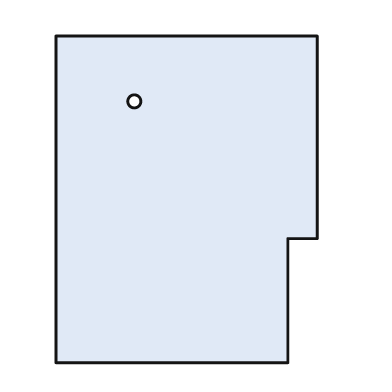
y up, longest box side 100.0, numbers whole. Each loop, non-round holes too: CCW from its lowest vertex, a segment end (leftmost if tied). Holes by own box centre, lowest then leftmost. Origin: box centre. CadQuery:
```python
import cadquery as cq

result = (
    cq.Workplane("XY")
    .moveTo(-40.0, -50.0)
    .lineTo(31.0, -50.0)
    .lineTo(31.0, -12.0)
    .lineTo(40.0, -12.0)
    .lineTo(40.0, 50.0)
    .lineTo(-40.0, 50.0)
    .close()
    .moveTo(-16.0, 30.0)
    .circle(2.0)
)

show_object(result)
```